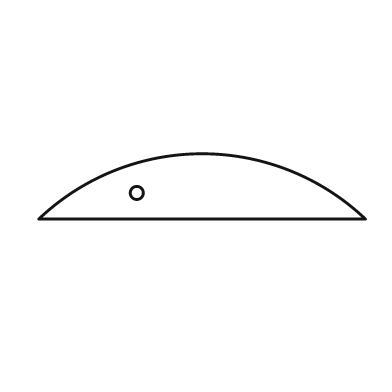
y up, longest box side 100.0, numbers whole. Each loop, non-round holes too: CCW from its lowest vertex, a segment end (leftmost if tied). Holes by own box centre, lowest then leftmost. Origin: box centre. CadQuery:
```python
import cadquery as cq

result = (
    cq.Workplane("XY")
    .moveTo(-50.0, -10.0)
    .lineTo(50.0, -10.0)
    .threePointArc((0.0, 10.0), (-50.0, -10.0))
    .close()
    .moveTo(-20.0, -2.0)
    .circle(2.0)
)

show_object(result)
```